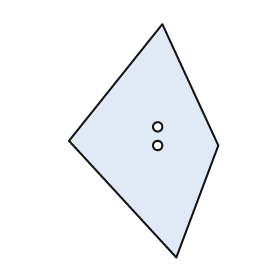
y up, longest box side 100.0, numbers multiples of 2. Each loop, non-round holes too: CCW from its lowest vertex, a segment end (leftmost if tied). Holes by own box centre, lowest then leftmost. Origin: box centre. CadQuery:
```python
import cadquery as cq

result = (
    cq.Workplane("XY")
    .moveTo(14.0, -50.0)
    .lineTo(32.0, -2.0)
    .lineTo(8.0, 50.0)
    .lineTo(-32.0, 0.0)
    .close()
    .moveTo(6.0, -2.0)
    .circle(2.0)
    .moveTo(6.0, 6.0)
    .circle(2.0)
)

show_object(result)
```